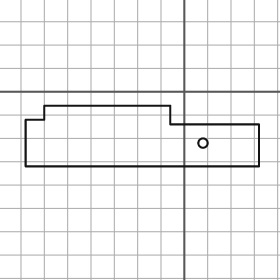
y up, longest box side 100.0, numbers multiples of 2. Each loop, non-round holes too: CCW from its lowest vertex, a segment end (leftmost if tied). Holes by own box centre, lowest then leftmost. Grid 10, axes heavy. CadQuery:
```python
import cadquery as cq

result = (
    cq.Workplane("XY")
    .moveTo(-68.0, -32.0)
    .lineTo(32.0, -32.0)
    .lineTo(32.0, -14.0)
    .lineTo(-6.0, -14.0)
    .lineTo(-6.0, -6.0)
    .lineTo(-60.0, -6.0)
    .lineTo(-60.0, -12.0)
    .lineTo(-68.0, -12.0)
    .close()
    .moveTo(8.0, -22.0)
    .circle(2.0)
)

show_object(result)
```